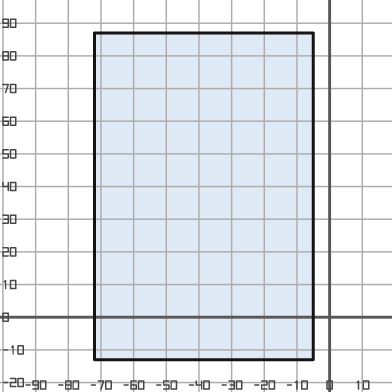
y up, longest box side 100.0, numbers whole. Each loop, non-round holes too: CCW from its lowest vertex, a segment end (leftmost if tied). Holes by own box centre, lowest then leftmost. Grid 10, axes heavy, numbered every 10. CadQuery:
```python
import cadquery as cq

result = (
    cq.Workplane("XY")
    .moveTo(-72.0, -13.0)
    .lineTo(-5.0, -13.0)
    .lineTo(-5.0, 87.0)
    .lineTo(-72.0, 87.0)
    .close()
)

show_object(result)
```